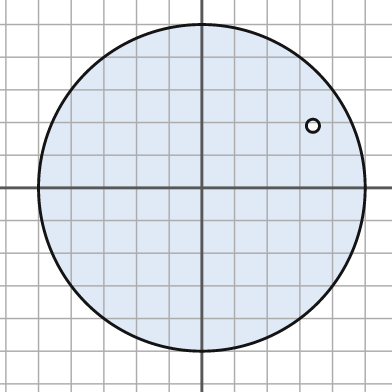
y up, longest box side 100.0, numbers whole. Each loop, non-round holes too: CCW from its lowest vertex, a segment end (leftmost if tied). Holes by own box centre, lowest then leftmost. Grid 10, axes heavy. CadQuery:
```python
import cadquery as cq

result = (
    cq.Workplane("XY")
    .moveTo(0.0, 0.0)
    .circle(50.0)
    .moveTo(34.0, 19.0)
    .circle(2.0)
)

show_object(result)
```